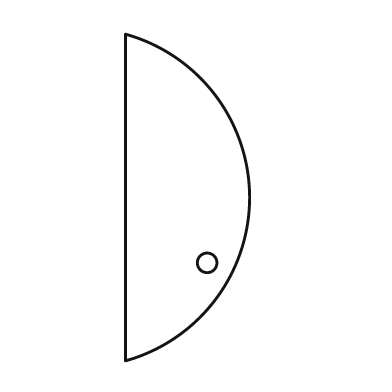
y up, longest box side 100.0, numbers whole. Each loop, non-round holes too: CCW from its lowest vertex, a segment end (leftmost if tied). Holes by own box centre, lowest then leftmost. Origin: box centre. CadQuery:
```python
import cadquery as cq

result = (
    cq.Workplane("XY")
    .moveTo(-19.0, -50.0)
    .threePointArc((19.0, 0.0), (-19.0, 50.0))
    .close()
    .moveTo(6.0, -20.0)
    .circle(3.0)
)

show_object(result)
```